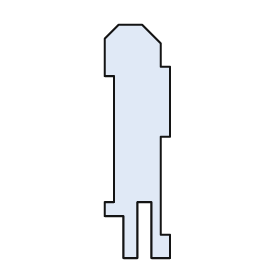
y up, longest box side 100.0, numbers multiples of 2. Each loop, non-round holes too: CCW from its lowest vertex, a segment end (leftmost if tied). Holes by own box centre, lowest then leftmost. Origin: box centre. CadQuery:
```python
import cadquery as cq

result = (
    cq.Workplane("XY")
    .moveTo(-6.0, -50.0)
    .lineTo(0.0, -50.0)
    .lineTo(0.0, -26.0)
    .lineTo(6.0, -26.0)
    .lineTo(6.0, -50.0)
    .lineTo(14.0, -50.0)
    .lineTo(14.0, -40.0)
    .lineTo(10.0, -40.0)
    .lineTo(10.0, 2.0)
    .lineTo(14.0, 2.0)
    .lineTo(14.0, 32.0)
    .lineTo(10.0, 32.0)
    .lineTo(10.0, 42.0)
    .lineTo(2.0, 50.0)
    .lineTo(-8.0, 50.0)
    .lineTo(-14.0, 44.0)
    .lineTo(-14.0, 28.0)
    .lineTo(-10.0, 28.0)
    .lineTo(-10.0, -26.0)
    .lineTo(-14.0, -26.0)
    .lineTo(-14.0, -32.0)
    .lineTo(-6.0, -32.0)
    .close()
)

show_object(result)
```